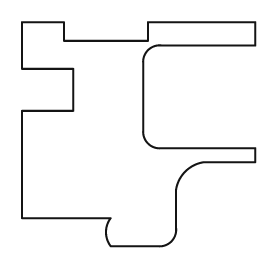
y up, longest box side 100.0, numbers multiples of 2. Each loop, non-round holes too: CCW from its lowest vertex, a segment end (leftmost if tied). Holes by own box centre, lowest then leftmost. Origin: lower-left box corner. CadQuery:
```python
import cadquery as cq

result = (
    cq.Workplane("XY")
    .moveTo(38.0, 0.0)
    .lineTo(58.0, 0.0)
    .threePointArc((64.0, 2.0), (66.0, 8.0))
    .lineTo(66.0, 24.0)
    .threePointArc((70.0, 32.0), (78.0, 36.0))
    .lineTo(100.0, 36.0)
    .lineTo(100.0, 42.0)
    .lineTo(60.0, 42.0)
    .threePointArc((54.0, 44.0), (52.0, 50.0))
    .lineTo(52.0, 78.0)
    .threePointArc((54.0, 84.0), (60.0, 86.0))
    .lineTo(100.0, 86.0)
    .lineTo(100.0, 96.0)
    .lineTo(54.0, 96.0)
    .lineTo(54.0, 88.0)
    .lineTo(18.0, 88.0)
    .lineTo(18.0, 96.0)
    .lineTo(0.0, 96.0)
    .lineTo(0.0, 76.0)
    .lineTo(22.0, 76.0)
    .lineTo(22.0, 58.0)
    .lineTo(0.0, 58.0)
    .lineTo(0.0, 12.0)
    .lineTo(38.0, 12.0)
    .threePointArc((36.0, 6.0), (38.0, 0.0))
    .close()
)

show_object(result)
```